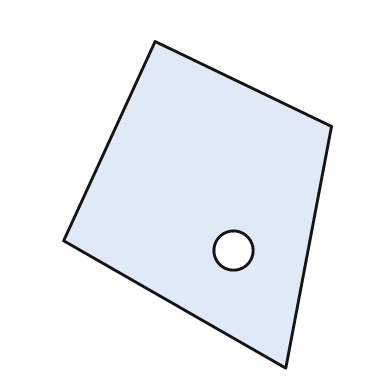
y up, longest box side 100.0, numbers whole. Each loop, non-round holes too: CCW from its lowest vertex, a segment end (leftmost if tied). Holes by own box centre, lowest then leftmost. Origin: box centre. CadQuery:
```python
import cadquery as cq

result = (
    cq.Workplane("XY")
    .moveTo(27.0, -50.0)
    .lineTo(41.0, 24.0)
    .lineTo(-13.0, 50.0)
    .lineTo(-41.0, -11.0)
    .close()
    .moveTo(11.0, -14.0)
    .circle(6.0)
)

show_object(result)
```